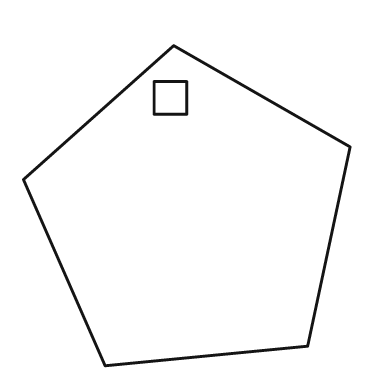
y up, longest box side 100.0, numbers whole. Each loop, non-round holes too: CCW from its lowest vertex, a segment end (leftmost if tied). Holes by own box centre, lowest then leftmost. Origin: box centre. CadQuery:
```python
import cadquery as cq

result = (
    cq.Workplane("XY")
    .moveTo(-25.0, -49.0)
    .lineTo(37.0, -43.0)
    .lineTo(50.0, 18.0)
    .lineTo(-4.0, 49.0)
    .lineTo(-50.0, 8.0)
    .close()
    .moveTo(-10.0, 28.0)
    .lineTo(0.0, 28.0)
    .lineTo(0.0, 38.0)
    .lineTo(-10.0, 38.0)
    .close()
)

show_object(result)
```